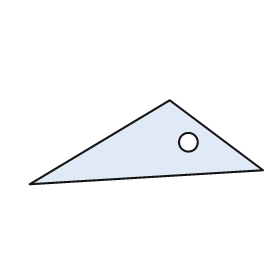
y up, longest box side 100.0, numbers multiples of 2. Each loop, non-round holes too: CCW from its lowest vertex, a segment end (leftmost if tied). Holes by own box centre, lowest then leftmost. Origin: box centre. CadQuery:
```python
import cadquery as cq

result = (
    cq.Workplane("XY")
    .moveTo(-50.0, -18.0)
    .lineTo(50.0, -12.0)
    .lineTo(10.0, 18.0)
    .close()
    .moveTo(18.0, 0.0)
    .circle(4.0)
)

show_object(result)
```